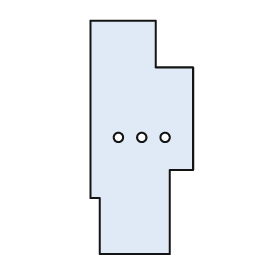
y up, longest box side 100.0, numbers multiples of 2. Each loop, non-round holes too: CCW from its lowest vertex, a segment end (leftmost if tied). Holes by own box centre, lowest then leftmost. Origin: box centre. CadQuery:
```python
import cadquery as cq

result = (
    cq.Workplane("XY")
    .moveTo(-18.0, -50.0)
    .lineTo(12.0, -50.0)
    .lineTo(12.0, -14.0)
    .lineTo(22.0, -14.0)
    .lineTo(22.0, 30.0)
    .lineTo(6.0, 30.0)
    .lineTo(6.0, 50.0)
    .lineTo(-22.0, 50.0)
    .lineTo(-22.0, -26.0)
    .lineTo(-18.0, -26.0)
    .close()
    .moveTo(-10.0, 0.0)
    .circle(2.0)
    .moveTo(0.0, 0.0)
    .circle(2.0)
    .moveTo(10.0, 0.0)
    .circle(2.0)
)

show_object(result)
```